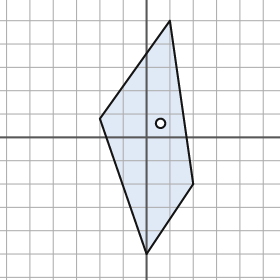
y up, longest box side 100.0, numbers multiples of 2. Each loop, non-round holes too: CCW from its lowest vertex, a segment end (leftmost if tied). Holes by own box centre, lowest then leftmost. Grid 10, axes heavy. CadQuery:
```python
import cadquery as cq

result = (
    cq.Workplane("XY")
    .moveTo(0.0, -50.0)
    .lineTo(20.0, -20.0)
    .lineTo(10.0, 50.0)
    .lineTo(-20.0, 8.0)
    .close()
    .moveTo(6.0, 6.0)
    .circle(2.0)
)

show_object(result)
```